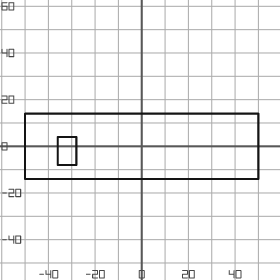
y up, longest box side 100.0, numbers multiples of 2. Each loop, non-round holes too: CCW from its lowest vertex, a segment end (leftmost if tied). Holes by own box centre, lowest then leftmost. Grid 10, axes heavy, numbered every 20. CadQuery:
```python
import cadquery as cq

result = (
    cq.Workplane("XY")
    .moveTo(-50.0, -14.0)
    .lineTo(50.0, -14.0)
    .lineTo(50.0, 14.0)
    .lineTo(-50.0, 14.0)
    .close()
    .moveTo(-36.0, -8.0)
    .lineTo(-28.0, -8.0)
    .lineTo(-28.0, 4.0)
    .lineTo(-36.0, 4.0)
    .close()
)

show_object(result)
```